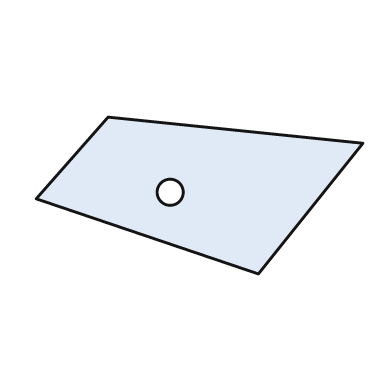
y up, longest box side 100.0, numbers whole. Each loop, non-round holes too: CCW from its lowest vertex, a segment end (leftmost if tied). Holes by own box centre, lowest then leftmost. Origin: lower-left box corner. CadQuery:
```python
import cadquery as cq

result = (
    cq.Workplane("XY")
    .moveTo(68.0, 0.0)
    .lineTo(100.0, 40.0)
    .lineTo(22.0, 48.0)
    .lineTo(0.0, 23.0)
    .close()
    .moveTo(41.0, 25.0)
    .circle(4.0)
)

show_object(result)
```